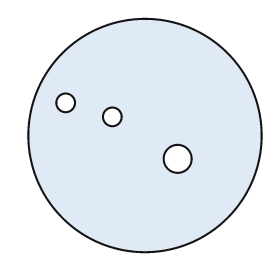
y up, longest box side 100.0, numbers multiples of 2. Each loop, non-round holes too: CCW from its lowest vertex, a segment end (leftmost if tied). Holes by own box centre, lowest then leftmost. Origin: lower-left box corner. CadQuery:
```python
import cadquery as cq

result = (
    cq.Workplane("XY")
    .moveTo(50.0, 50.0)
    .circle(50.0)
    .moveTo(64.0, 40.0)
    .circle(6.0)
    .moveTo(36.0, 58.0)
    .circle(4.0)
    .moveTo(16.0, 64.0)
    .circle(4.0)
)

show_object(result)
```